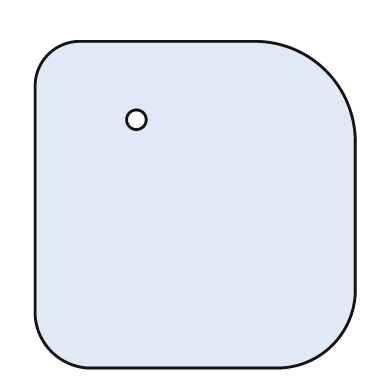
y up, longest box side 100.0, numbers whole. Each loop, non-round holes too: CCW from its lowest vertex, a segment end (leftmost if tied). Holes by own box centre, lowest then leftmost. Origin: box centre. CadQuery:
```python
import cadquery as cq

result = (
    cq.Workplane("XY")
    .moveTo(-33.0, -50.0)
    .lineTo(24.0, -50.0)
    .threePointArc((42.0, -43.0), (49.0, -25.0))
    .lineTo(49.0, 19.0)
    .threePointArc((40.0, 41.0), (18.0, 50.0))
    .lineTo(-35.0, 50.0)
    .threePointArc((-45.0, 46.0), (-49.0, 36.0))
    .lineTo(-49.0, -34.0)
    .threePointArc((-44.0, -45.0), (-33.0, -50.0))
    .close()
    .moveTo(-18.0, 26.0)
    .circle(3.0)
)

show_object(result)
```